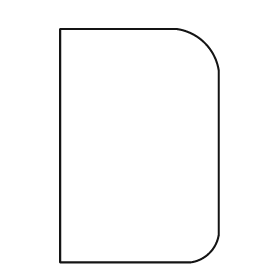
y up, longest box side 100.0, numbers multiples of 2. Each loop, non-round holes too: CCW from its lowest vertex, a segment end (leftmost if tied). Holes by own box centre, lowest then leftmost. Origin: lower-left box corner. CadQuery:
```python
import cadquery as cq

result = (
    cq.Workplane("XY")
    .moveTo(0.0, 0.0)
    .lineTo(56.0, 0.0)
    .threePointArc((64.0, 4.0), (68.0, 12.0))
    .lineTo(68.0, 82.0)
    .threePointArc((62.0, 94.0), (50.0, 100.0))
    .lineTo(0.0, 100.0)
    .close()
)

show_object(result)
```